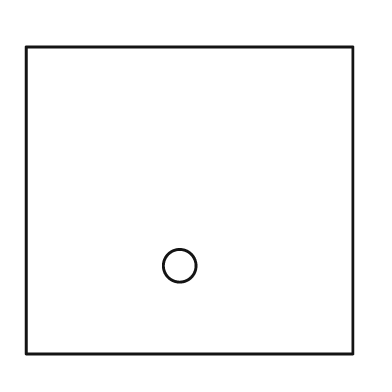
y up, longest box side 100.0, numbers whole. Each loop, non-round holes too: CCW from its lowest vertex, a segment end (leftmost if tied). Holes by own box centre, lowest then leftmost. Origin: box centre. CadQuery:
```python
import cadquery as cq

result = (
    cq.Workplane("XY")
    .moveTo(-50.0, -47.0)
    .lineTo(50.0, -47.0)
    .lineTo(50.0, 47.0)
    .lineTo(-50.0, 47.0)
    .close()
    .moveTo(-3.0, -20.0)
    .circle(5.0)
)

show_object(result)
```